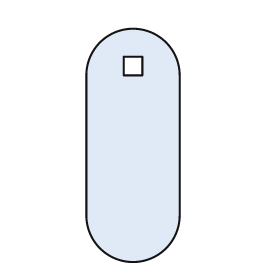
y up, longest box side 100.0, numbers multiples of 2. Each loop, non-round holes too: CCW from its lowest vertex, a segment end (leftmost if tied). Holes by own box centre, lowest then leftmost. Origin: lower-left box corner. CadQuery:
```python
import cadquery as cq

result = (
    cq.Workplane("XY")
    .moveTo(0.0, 20.0)
    .threePointArc((20.0, 0.0), (40.0, 20.0))
    .lineTo(40.0, 80.0)
    .threePointArc((20.0, 100.0), (0.0, 80.0))
    .close()
    .moveTo(16.0, 80.0)
    .lineTo(24.0, 80.0)
    .lineTo(24.0, 88.0)
    .lineTo(16.0, 88.0)
    .close()
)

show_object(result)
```